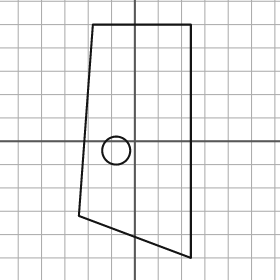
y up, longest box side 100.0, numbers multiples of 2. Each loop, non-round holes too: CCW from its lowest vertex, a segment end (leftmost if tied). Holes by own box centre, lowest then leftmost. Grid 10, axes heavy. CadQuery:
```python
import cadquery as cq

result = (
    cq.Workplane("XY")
    .moveTo(24.0, -50.0)
    .lineTo(24.0, 50.0)
    .lineTo(-18.0, 50.0)
    .lineTo(-24.0, -32.0)
    .close()
    .moveTo(-8.0, -4.0)
    .circle(6.0)
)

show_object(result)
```